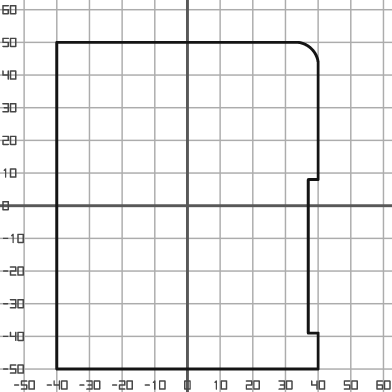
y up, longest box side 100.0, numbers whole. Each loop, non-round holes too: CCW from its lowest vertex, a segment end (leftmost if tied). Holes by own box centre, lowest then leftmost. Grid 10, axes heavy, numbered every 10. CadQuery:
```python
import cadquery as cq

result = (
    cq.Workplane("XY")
    .moveTo(-40.0, -50.0)
    .lineTo(40.0, -50.0)
    .lineTo(40.0, -39.0)
    .lineTo(37.0, -39.0)
    .lineTo(37.0, 8.0)
    .lineTo(40.0, 8.0)
    .lineTo(40.0, 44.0)
    .threePointArc((38.0, 48.0), (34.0, 50.0))
    .lineTo(-40.0, 50.0)
    .close()
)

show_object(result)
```